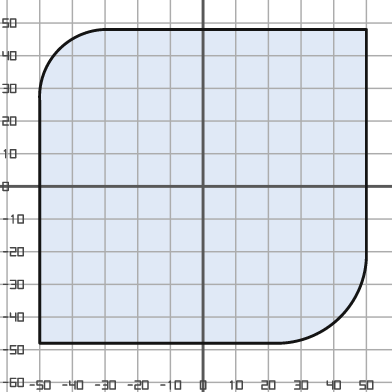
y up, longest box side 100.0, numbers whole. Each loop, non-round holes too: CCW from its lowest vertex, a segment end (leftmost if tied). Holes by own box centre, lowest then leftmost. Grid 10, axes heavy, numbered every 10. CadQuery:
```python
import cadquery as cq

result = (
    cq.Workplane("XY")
    .moveTo(-50.0, -48.0)
    .lineTo(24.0, -48.0)
    .threePointArc((42.0, -40.0), (50.0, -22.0))
    .lineTo(50.0, 48.0)
    .lineTo(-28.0, 48.0)
    .threePointArc((-44.0, 42.0), (-50.0, 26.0))
    .close()
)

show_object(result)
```